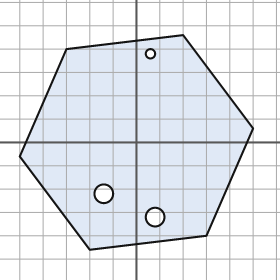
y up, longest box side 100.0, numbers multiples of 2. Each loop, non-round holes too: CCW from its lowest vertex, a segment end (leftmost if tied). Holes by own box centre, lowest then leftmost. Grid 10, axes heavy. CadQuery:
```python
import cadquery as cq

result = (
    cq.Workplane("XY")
    .moveTo(-20.0, -46.0)
    .lineTo(30.0, -40.0)
    .lineTo(50.0, 6.0)
    .lineTo(20.0, 46.0)
    .lineTo(-30.0, 40.0)
    .lineTo(-50.0, -6.0)
    .close()
    .moveTo(8.0, -32.0)
    .circle(4.0)
    .moveTo(-14.0, -22.0)
    .circle(4.0)
    .moveTo(6.0, 38.0)
    .circle(2.0)
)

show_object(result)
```